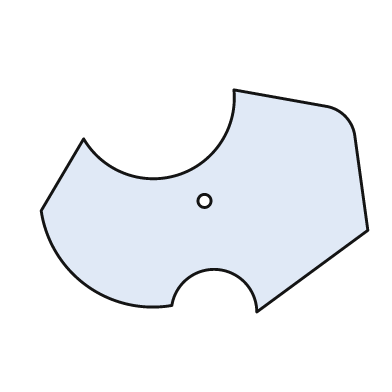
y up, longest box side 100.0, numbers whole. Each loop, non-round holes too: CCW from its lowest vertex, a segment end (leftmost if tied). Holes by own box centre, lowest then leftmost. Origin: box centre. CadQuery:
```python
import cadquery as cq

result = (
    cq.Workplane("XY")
    .moveTo(16.0, -34.0)
    .lineTo(50.0, -9.0)
    .lineTo(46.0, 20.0)
    .threePointArc((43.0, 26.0), (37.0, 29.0))
    .lineTo(9.0, 34.0)
    .threePointArc((-8.0, 8.0), (-37.0, 19.0))
    .lineTo(-50.0, -3.0)
    .threePointArc((-36.0, -26.0), (-10.0, -32.0))
    .threePointArc((4.0, -21.0), (16.0, -34.0))
    .close()
    .moveTo(0.0, 0.0)
    .circle(2.0)
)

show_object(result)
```